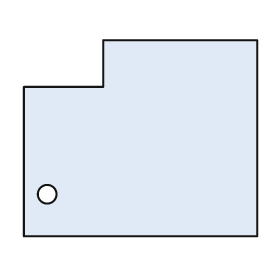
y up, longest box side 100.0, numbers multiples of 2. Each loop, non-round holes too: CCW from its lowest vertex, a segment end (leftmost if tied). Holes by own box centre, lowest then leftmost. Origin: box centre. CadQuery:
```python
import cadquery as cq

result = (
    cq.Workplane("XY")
    .moveTo(-50.0, -42.0)
    .lineTo(50.0, -42.0)
    .lineTo(50.0, 42.0)
    .lineTo(-16.0, 42.0)
    .lineTo(-16.0, 22.0)
    .lineTo(-50.0, 22.0)
    .close()
    .moveTo(-40.0, -24.0)
    .circle(4.0)
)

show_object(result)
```